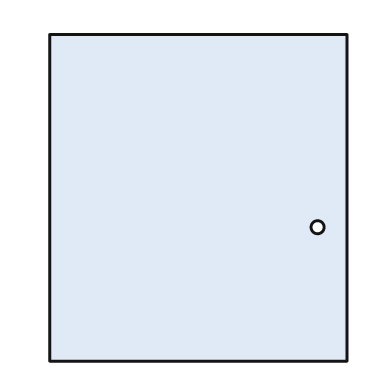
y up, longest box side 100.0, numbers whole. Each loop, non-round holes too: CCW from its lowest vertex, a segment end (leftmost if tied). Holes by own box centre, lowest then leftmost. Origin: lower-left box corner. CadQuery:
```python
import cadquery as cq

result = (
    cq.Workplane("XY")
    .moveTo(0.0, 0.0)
    .lineTo(91.0, 0.0)
    .lineTo(91.0, 100.0)
    .lineTo(0.0, 100.0)
    .close()
    .moveTo(82.0, 41.0)
    .circle(2.0)
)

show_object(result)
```